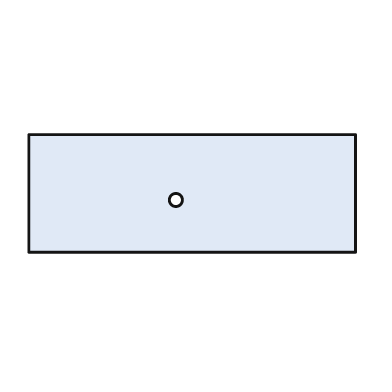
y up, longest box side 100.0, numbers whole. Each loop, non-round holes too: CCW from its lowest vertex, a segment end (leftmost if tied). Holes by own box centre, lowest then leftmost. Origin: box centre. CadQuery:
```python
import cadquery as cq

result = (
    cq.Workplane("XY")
    .moveTo(-50.0, -18.0)
    .lineTo(50.0, -18.0)
    .lineTo(50.0, 18.0)
    .lineTo(-50.0, 18.0)
    .close()
    .moveTo(-5.0, -2.0)
    .circle(2.0)
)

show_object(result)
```